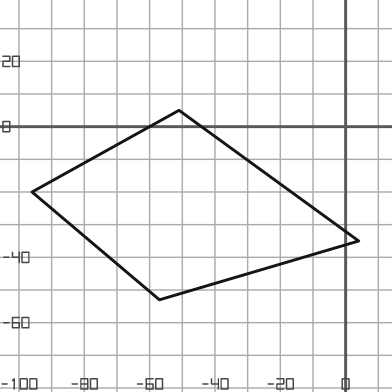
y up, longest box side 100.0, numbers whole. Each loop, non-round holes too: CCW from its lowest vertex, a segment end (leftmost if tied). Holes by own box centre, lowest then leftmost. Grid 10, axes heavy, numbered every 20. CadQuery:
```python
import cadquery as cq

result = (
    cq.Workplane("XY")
    .moveTo(-57.0, -53.0)
    .lineTo(4.0, -35.0)
    .lineTo(-51.0, 5.0)
    .lineTo(-96.0, -20.0)
    .close()
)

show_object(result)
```